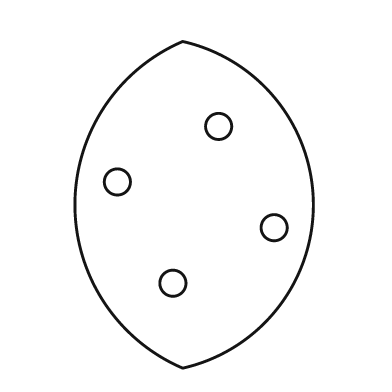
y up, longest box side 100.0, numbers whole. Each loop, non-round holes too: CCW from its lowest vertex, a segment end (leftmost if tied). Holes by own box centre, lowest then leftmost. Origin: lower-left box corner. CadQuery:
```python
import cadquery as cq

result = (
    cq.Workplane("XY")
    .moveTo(33.0, 0.0)
    .threePointArc((73.0, 50.0), (33.0, 100.0))
    .threePointArc((0.0, 50.0), (33.0, 0.0))
    .close()
    .moveTo(30.0, 26.0)
    .circle(4.0)
    .moveTo(61.0, 43.0)
    .circle(4.0)
    .moveTo(13.0, 57.0)
    .circle(4.0)
    .moveTo(44.0, 74.0)
    .circle(4.0)
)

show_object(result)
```